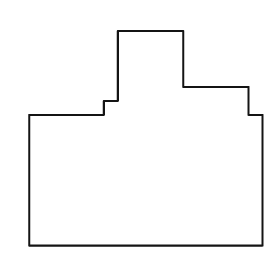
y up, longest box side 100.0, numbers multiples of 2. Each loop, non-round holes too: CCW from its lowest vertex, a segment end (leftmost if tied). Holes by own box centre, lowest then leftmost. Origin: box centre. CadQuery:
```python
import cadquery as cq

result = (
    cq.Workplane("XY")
    .moveTo(-50.0, -46.0)
    .lineTo(50.0, -46.0)
    .lineTo(50.0, 10.0)
    .lineTo(44.0, 10.0)
    .lineTo(44.0, 22.0)
    .lineTo(16.0, 22.0)
    .lineTo(16.0, 46.0)
    .lineTo(-12.0, 46.0)
    .lineTo(-12.0, 16.0)
    .lineTo(-18.0, 16.0)
    .lineTo(-18.0, 10.0)
    .lineTo(-50.0, 10.0)
    .close()
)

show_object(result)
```